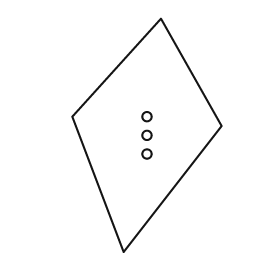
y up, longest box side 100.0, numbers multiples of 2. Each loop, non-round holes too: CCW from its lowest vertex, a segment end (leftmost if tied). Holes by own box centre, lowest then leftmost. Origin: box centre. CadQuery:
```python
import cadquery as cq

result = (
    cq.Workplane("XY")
    .moveTo(-10.0, -50.0)
    .lineTo(32.0, 4.0)
    .lineTo(6.0, 50.0)
    .lineTo(-32.0, 8.0)
    .close()
    .moveTo(0.0, -8.0)
    .circle(2.0)
    .moveTo(0.0, 0.0)
    .circle(2.0)
    .moveTo(0.0, 8.0)
    .circle(2.0)
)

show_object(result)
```